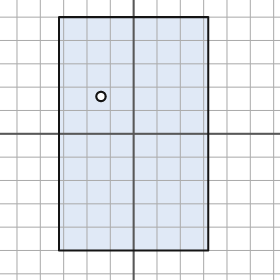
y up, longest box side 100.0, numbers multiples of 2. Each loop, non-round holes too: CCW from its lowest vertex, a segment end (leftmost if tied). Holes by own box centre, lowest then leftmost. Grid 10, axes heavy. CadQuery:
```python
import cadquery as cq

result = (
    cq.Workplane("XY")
    .moveTo(-32.0, -50.0)
    .lineTo(32.0, -50.0)
    .lineTo(32.0, 50.0)
    .lineTo(-32.0, 50.0)
    .close()
    .moveTo(-14.0, 16.0)
    .circle(2.0)
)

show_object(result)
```